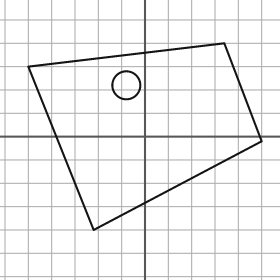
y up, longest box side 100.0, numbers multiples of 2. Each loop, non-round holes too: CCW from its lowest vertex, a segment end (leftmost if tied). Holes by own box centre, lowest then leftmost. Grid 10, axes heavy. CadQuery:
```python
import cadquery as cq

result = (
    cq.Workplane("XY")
    .moveTo(-22.0, -40.0)
    .lineTo(50.0, -2.0)
    .lineTo(34.0, 40.0)
    .lineTo(-50.0, 30.0)
    .close()
    .moveTo(-8.0, 22.0)
    .circle(6.0)
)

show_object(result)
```